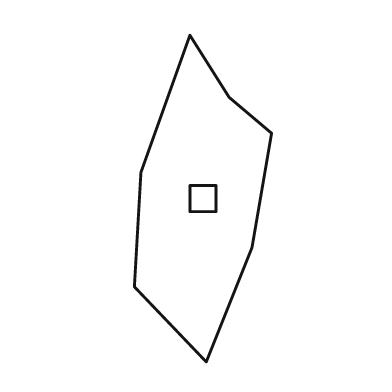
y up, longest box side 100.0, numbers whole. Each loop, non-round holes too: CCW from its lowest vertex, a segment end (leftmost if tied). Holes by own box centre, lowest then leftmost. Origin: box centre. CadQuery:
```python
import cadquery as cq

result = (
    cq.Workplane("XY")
    .moveTo(1.0, -50.0)
    .lineTo(15.0, -15.0)
    .lineTo(21.0, 20.0)
    .lineTo(8.0, 31.0)
    .lineTo(-4.0, 50.0)
    .lineTo(-19.0, 8.0)
    .lineTo(-21.0, -27.0)
    .close()
    .moveTo(-4.0, -4.0)
    .lineTo(4.0, -4.0)
    .lineTo(4.0, 4.0)
    .lineTo(-4.0, 4.0)
    .close()
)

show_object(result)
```